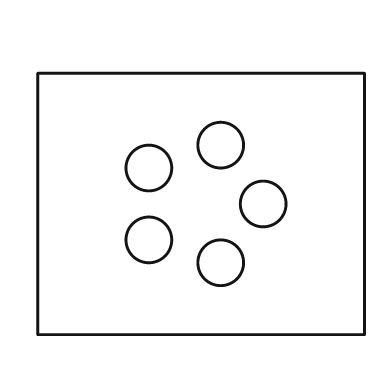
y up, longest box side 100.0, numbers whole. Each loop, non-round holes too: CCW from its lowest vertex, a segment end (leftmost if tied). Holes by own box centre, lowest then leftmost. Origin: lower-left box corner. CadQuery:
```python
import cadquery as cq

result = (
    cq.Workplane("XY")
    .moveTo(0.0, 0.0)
    .lineTo(100.0, 0.0)
    .lineTo(100.0, 80.0)
    .lineTo(0.0, 80.0)
    .close()
    .moveTo(56.0, 22.0)
    .circle(7.0)
    .moveTo(34.0, 29.0)
    .circle(7.0)
    .moveTo(69.0, 40.0)
    .circle(7.0)
    .moveTo(34.0, 51.0)
    .circle(7.0)
    .moveTo(56.0, 58.0)
    .circle(7.0)
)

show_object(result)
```